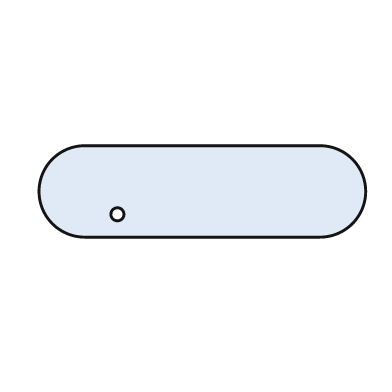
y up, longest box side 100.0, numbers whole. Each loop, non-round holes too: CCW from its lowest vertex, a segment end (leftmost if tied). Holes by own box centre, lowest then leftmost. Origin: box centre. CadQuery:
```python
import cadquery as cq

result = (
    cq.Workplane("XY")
    .moveTo(-36.0, -14.0)
    .lineTo(36.0, -14.0)
    .threePointArc((50.0, 0.0), (36.0, 14.0))
    .lineTo(-36.0, 14.0)
    .threePointArc((-50.0, 0.0), (-36.0, -14.0))
    .close()
    .moveTo(-26.0, -7.0)
    .circle(2.0)
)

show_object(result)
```